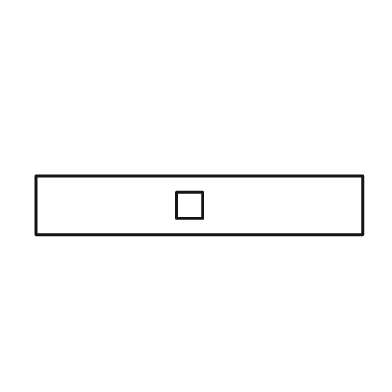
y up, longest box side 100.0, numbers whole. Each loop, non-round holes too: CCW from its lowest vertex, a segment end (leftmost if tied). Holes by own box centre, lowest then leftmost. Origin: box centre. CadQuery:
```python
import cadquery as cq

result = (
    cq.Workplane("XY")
    .moveTo(-50.0, -9.0)
    .lineTo(50.0, -9.0)
    .lineTo(50.0, 9.0)
    .lineTo(-50.0, 9.0)
    .close()
    .moveTo(-7.0, -4.0)
    .lineTo(1.0, -4.0)
    .lineTo(1.0, 4.0)
    .lineTo(-7.0, 4.0)
    .close()
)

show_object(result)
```